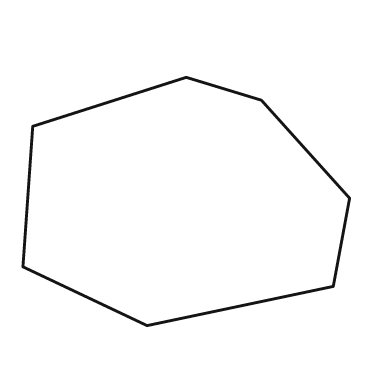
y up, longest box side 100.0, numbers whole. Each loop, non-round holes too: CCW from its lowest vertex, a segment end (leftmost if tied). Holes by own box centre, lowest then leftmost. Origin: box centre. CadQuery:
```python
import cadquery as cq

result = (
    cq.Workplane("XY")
    .moveTo(-12.0, -38.0)
    .lineTo(45.0, -26.0)
    .lineTo(50.0, 1.0)
    .lineTo(23.0, 31.0)
    .lineTo(0.0, 38.0)
    .lineTo(-47.0, 23.0)
    .lineTo(-50.0, -20.0)
    .close()
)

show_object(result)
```